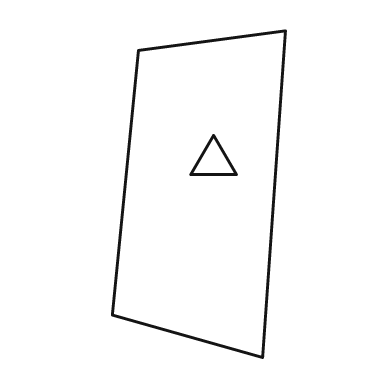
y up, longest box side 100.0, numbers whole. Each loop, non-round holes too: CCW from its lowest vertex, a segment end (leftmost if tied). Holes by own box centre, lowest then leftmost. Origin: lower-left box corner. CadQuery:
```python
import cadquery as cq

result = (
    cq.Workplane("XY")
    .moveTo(46.0, 0.0)
    .lineTo(53.0, 100.0)
    .lineTo(8.0, 94.0)
    .lineTo(0.0, 13.0)
    .close()
    .moveTo(24.0, 56.0)
    .lineTo(38.0, 56.0)
    .lineTo(31.0, 68.0)
    .close()
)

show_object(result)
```